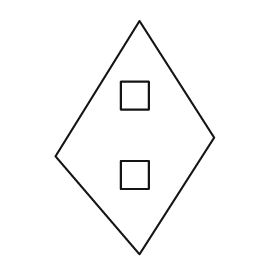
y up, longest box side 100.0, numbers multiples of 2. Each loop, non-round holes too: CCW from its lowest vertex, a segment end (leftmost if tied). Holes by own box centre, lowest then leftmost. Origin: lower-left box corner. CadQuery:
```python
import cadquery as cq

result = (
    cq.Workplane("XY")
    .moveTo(36.0, 0.0)
    .lineTo(68.0, 50.0)
    .lineTo(36.0, 100.0)
    .lineTo(0.0, 42.0)
    .close()
    .moveTo(28.0, 28.0)
    .lineTo(40.0, 28.0)
    .lineTo(40.0, 40.0)
    .lineTo(28.0, 40.0)
    .close()
    .moveTo(28.0, 62.0)
    .lineTo(40.0, 62.0)
    .lineTo(40.0, 74.0)
    .lineTo(28.0, 74.0)
    .close()
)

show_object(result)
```